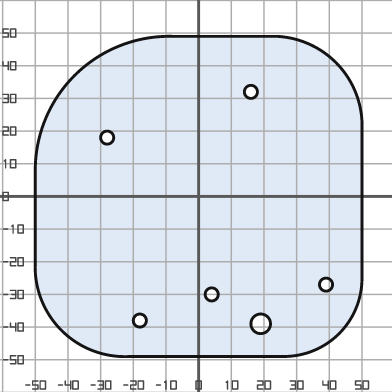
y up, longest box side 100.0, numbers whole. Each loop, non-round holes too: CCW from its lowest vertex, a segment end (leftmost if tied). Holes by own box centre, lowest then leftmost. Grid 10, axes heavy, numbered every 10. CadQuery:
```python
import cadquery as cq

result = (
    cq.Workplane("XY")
    .moveTo(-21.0, -49.0)
    .lineTo(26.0, -49.0)
    .threePointArc((43.0, -42.0), (50.0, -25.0))
    .lineTo(50.0, 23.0)
    .threePointArc((42.0, 41.0), (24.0, 49.0))
    .lineTo(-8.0, 49.0)
    .threePointArc((-38.0, 37.0), (-50.0, 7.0))
    .lineTo(-50.0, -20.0)
    .threePointArc((-42.0, -41.0), (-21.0, -49.0))
    .close()
    .moveTo(19.0, -39.0)
    .circle(3.0)
    .moveTo(-18.0, -38.0)
    .circle(2.0)
    .moveTo(4.0, -30.0)
    .circle(2.0)
    .moveTo(39.0, -27.0)
    .circle(2.0)
    .moveTo(-28.0, 18.0)
    .circle(2.0)
    .moveTo(16.0, 32.0)
    .circle(2.0)
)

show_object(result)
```